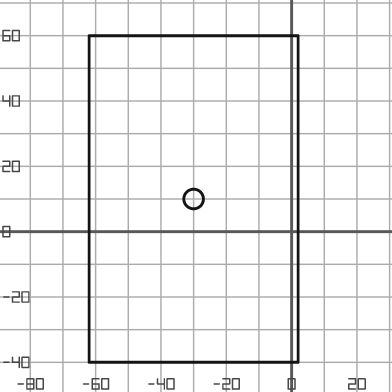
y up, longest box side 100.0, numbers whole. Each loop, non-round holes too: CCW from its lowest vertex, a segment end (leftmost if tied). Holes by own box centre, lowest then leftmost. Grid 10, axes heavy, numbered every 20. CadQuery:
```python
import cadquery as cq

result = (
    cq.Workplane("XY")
    .moveTo(-62.0, -40.0)
    .lineTo(2.0, -40.0)
    .lineTo(2.0, 60.0)
    .lineTo(-62.0, 60.0)
    .close()
    .moveTo(-30.0, 10.0)
    .circle(3.0)
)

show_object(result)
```